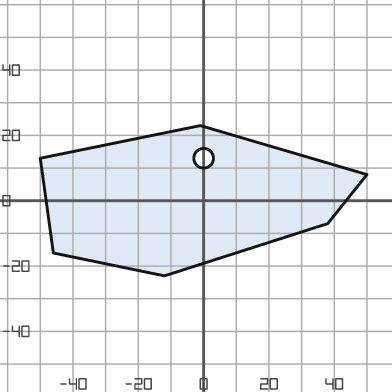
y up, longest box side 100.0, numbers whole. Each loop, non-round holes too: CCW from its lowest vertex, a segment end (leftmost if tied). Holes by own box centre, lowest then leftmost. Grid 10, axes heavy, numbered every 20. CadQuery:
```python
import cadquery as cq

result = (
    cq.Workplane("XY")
    .moveTo(-12.0, -23.0)
    .lineTo(38.0, -7.0)
    .lineTo(50.0, 8.0)
    .lineTo(-1.0, 23.0)
    .lineTo(-50.0, 13.0)
    .lineTo(-46.0, -16.0)
    .close()
    .moveTo(0.0, 13.0)
    .circle(3.0)
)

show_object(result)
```